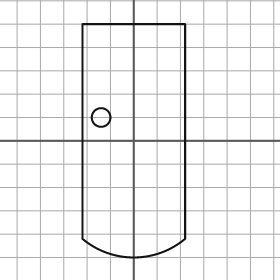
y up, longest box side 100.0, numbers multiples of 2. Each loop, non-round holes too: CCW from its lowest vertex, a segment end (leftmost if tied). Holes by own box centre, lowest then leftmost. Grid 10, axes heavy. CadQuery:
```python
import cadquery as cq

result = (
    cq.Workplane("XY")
    .moveTo(-22.0, -42.0)
    .threePointArc((0.0, -50.0), (22.0, -42.0))
    .lineTo(22.0, 50.0)
    .lineTo(-22.0, 50.0)
    .close()
    .moveTo(-14.0, 10.0)
    .circle(4.0)
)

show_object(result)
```